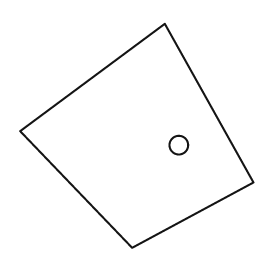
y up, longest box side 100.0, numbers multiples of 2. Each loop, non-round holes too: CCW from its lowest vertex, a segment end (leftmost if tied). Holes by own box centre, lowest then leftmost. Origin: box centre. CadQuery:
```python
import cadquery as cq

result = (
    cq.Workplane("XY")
    .moveTo(-2.0, -48.0)
    .lineTo(50.0, -20.0)
    .lineTo(12.0, 48.0)
    .lineTo(-50.0, 2.0)
    .close()
    .moveTo(18.0, -4.0)
    .circle(4.0)
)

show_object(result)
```